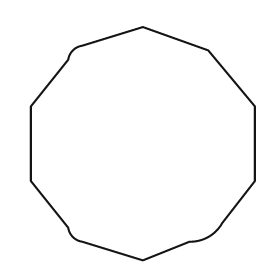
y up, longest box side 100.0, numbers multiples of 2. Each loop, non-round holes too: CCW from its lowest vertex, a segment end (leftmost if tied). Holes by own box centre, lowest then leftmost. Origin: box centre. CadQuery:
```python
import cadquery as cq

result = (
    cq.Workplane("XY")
    .moveTo(0.0, -50.0)
    .lineTo(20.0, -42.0)
    .threePointArc((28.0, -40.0), (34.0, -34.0))
    .lineTo(48.0, -16.0)
    .lineTo(48.0, 16.0)
    .lineTo(28.0, 40.0)
    .lineTo(0.0, 50.0)
    .lineTo(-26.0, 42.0)
    .threePointArc((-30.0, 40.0), (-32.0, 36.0))
    .lineTo(-48.0, 16.0)
    .lineTo(-48.0, -16.0)
    .lineTo(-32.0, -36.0)
    .threePointArc((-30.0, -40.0), (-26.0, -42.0))
    .close()
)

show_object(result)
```